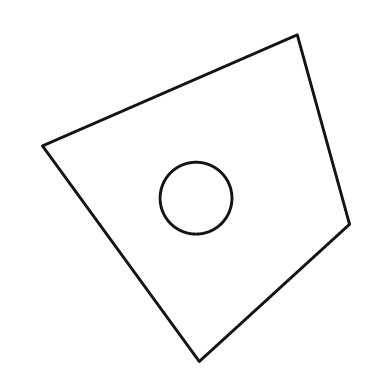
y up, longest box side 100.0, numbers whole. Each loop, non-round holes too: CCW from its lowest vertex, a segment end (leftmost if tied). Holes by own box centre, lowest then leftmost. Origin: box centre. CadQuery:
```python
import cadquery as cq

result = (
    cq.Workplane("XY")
    .moveTo(1.0, -50.0)
    .lineTo(47.0, -8.0)
    .lineTo(31.0, 50.0)
    .lineTo(-47.0, 16.0)
    .close()
    .moveTo(0.0, 0.0)
    .circle(11.0)
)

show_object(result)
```